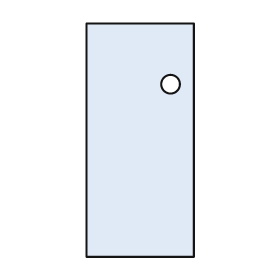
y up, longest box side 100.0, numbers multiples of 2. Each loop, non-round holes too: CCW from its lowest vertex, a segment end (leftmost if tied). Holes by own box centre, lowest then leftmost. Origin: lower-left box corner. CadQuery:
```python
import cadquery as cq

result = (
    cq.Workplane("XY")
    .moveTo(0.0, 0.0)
    .lineTo(46.0, 0.0)
    .lineTo(46.0, 100.0)
    .lineTo(0.0, 100.0)
    .close()
    .moveTo(36.0, 74.0)
    .circle(4.0)
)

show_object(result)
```